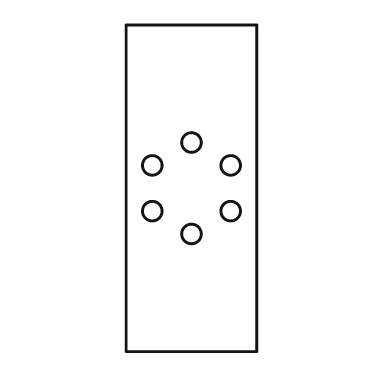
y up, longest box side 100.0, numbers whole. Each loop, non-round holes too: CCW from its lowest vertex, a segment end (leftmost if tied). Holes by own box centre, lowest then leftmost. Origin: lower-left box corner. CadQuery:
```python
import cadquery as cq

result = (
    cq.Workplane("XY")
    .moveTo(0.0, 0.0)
    .lineTo(40.0, 0.0)
    .lineTo(40.0, 100.0)
    .lineTo(0.0, 100.0)
    .close()
    .moveTo(20.0, 36.0)
    .circle(3.0)
    .moveTo(8.0, 43.0)
    .circle(3.0)
    .moveTo(32.0, 43.0)
    .circle(3.0)
    .moveTo(8.0, 57.0)
    .circle(3.0)
    .moveTo(32.0, 57.0)
    .circle(3.0)
    .moveTo(20.0, 64.0)
    .circle(3.0)
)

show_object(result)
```